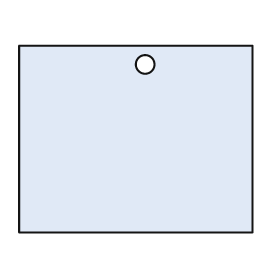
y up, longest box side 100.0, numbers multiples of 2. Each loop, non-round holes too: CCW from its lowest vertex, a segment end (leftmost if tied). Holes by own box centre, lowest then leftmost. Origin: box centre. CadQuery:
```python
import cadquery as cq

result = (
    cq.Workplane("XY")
    .moveTo(-50.0, -40.0)
    .lineTo(50.0, -40.0)
    .lineTo(50.0, 40.0)
    .lineTo(-50.0, 40.0)
    .close()
    .moveTo(4.0, 32.0)
    .circle(4.0)
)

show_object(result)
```